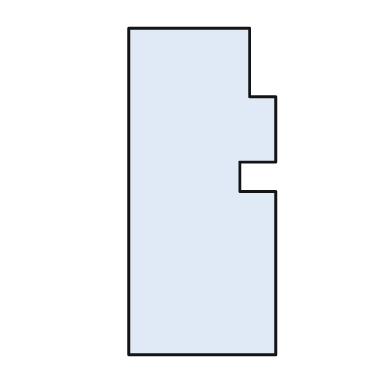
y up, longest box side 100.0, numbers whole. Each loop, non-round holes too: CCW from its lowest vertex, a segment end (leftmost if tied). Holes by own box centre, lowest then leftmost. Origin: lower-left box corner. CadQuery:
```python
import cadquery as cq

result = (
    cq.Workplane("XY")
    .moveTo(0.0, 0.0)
    .lineTo(45.0, 0.0)
    .lineTo(45.0, 50.0)
    .lineTo(34.0, 50.0)
    .lineTo(34.0, 59.0)
    .lineTo(45.0, 59.0)
    .lineTo(45.0, 79.0)
    .lineTo(37.0, 79.0)
    .lineTo(37.0, 100.0)
    .lineTo(0.0, 100.0)
    .close()
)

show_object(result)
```